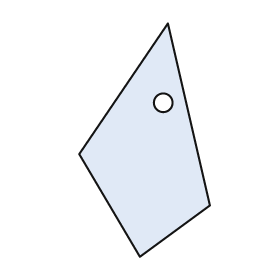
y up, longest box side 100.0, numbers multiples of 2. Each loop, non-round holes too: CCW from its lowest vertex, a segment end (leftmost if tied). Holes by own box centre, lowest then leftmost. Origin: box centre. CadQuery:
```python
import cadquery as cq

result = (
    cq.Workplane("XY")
    .moveTo(-2.0, -50.0)
    .lineTo(28.0, -28.0)
    .lineTo(10.0, 50.0)
    .lineTo(-28.0, -6.0)
    .close()
    .moveTo(8.0, 16.0)
    .circle(4.0)
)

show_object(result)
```